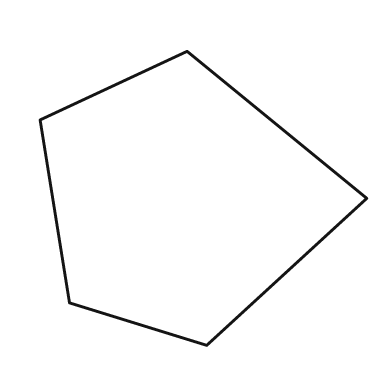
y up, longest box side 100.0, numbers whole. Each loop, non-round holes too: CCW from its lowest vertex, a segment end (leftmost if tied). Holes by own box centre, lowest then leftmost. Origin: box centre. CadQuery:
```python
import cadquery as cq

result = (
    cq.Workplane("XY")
    .moveTo(1.0, -45.0)
    .lineTo(50.0, 0.0)
    .lineTo(-5.0, 45.0)
    .lineTo(-50.0, 24.0)
    .lineTo(-41.0, -32.0)
    .close()
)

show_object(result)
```